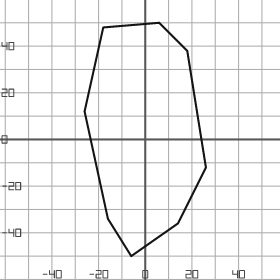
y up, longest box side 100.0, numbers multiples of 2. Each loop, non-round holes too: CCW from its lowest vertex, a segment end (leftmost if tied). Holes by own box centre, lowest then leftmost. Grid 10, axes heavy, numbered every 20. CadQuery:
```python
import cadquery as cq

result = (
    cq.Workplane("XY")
    .moveTo(-6.0, -50.0)
    .lineTo(14.0, -36.0)
    .lineTo(26.0, -12.0)
    .lineTo(18.0, 38.0)
    .lineTo(6.0, 50.0)
    .lineTo(-18.0, 48.0)
    .lineTo(-26.0, 12.0)
    .lineTo(-16.0, -34.0)
    .close()
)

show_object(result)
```